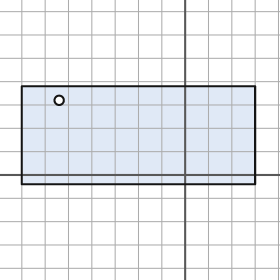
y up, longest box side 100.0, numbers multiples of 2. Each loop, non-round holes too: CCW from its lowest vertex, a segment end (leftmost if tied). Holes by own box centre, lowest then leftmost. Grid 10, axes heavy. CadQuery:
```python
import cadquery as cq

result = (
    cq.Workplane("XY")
    .moveTo(-70.0, -4.0)
    .lineTo(30.0, -4.0)
    .lineTo(30.0, 38.0)
    .lineTo(-70.0, 38.0)
    .close()
    .moveTo(-54.0, 32.0)
    .circle(2.0)
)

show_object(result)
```